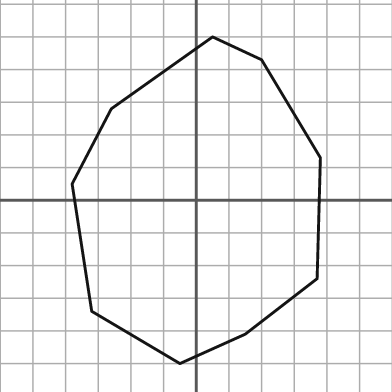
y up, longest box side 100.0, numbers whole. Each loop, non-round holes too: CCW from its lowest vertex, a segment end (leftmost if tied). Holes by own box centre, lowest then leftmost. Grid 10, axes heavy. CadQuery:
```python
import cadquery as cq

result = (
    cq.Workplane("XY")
    .moveTo(-5.0, -50.0)
    .lineTo(15.0, -41.0)
    .lineTo(37.0, -24.0)
    .lineTo(38.0, 13.0)
    .lineTo(20.0, 43.0)
    .lineTo(5.0, 50.0)
    .lineTo(-26.0, 28.0)
    .lineTo(-38.0, 5.0)
    .lineTo(-32.0, -34.0)
    .close()
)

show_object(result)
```